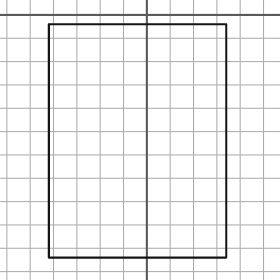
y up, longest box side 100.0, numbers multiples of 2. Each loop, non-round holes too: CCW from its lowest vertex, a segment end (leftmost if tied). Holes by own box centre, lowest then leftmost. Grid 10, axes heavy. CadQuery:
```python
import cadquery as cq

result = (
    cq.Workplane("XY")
    .moveTo(-42.0, -104.0)
    .lineTo(34.0, -104.0)
    .lineTo(34.0, -4.0)
    .lineTo(-42.0, -4.0)
    .close()
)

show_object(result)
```